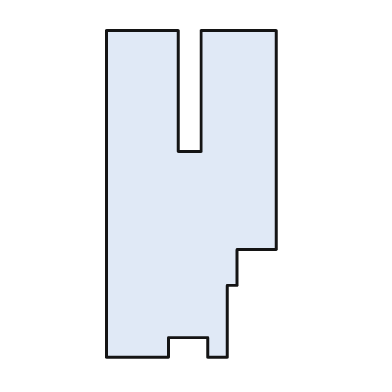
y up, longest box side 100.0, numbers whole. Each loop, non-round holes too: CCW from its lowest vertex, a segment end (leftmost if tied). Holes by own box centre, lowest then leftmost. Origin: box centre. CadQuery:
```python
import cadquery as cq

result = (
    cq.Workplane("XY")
    .moveTo(-26.0, -50.0)
    .lineTo(-7.0, -50.0)
    .lineTo(-7.0, -44.0)
    .lineTo(5.0, -44.0)
    .lineTo(5.0, -50.0)
    .lineTo(11.0, -50.0)
    .lineTo(11.0, -28.0)
    .lineTo(14.0, -28.0)
    .lineTo(14.0, -17.0)
    .lineTo(26.0, -17.0)
    .lineTo(26.0, 50.0)
    .lineTo(3.0, 50.0)
    .lineTo(3.0, 13.0)
    .lineTo(-4.0, 13.0)
    .lineTo(-4.0, 50.0)
    .lineTo(-26.0, 50.0)
    .close()
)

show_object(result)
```